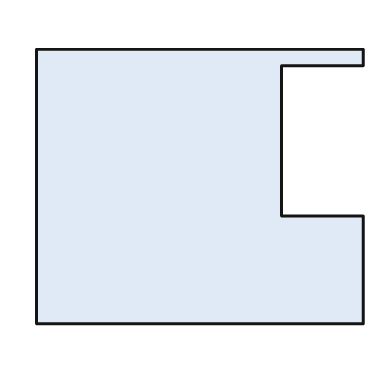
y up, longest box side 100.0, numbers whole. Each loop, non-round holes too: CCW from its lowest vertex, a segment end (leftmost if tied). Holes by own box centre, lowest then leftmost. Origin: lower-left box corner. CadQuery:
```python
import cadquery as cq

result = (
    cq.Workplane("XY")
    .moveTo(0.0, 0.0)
    .lineTo(100.0, 0.0)
    .lineTo(100.0, 33.0)
    .lineTo(75.0, 33.0)
    .lineTo(75.0, 79.0)
    .lineTo(100.0, 79.0)
    .lineTo(100.0, 84.0)
    .lineTo(0.0, 84.0)
    .close()
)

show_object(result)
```